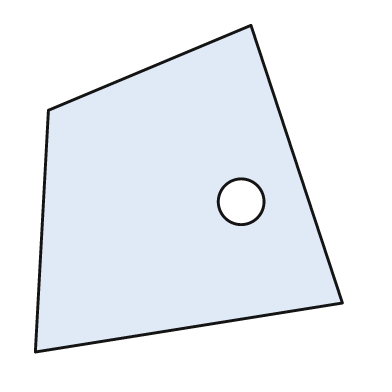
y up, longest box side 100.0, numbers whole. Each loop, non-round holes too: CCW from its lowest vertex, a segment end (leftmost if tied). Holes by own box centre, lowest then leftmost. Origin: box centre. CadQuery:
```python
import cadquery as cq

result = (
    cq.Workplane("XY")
    .moveTo(-47.0, -50.0)
    .lineTo(47.0, -35.0)
    .lineTo(19.0, 50.0)
    .lineTo(-43.0, 24.0)
    .close()
    .moveTo(16.0, -4.0)
    .circle(7.0)
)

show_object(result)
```